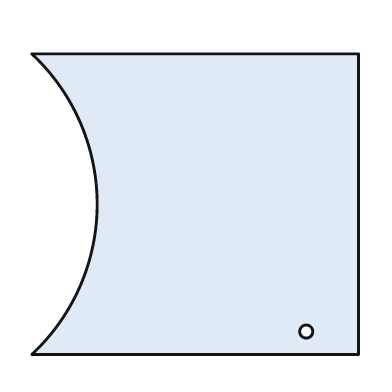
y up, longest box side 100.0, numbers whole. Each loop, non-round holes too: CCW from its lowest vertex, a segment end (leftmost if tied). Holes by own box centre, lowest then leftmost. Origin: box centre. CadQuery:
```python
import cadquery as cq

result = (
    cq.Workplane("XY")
    .moveTo(-50.0, -46.0)
    .lineTo(50.0, -46.0)
    .lineTo(50.0, 46.0)
    .lineTo(-50.0, 46.0)
    .threePointArc((-30.0, 0.0), (-50.0, -46.0))
    .close()
    .moveTo(34.0, -39.0)
    .circle(2.0)
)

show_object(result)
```